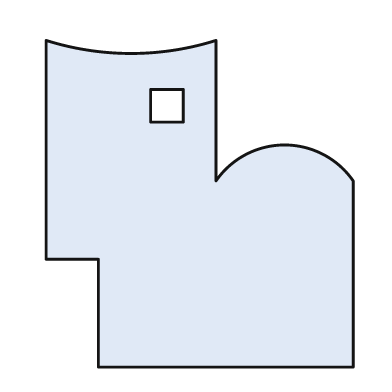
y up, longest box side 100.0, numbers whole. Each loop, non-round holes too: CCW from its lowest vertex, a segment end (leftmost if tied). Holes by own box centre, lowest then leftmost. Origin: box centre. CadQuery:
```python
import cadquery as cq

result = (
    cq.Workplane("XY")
    .moveTo(-31.0, -50.0)
    .lineTo(47.0, -50.0)
    .lineTo(47.0, 7.0)
    .threePointArc((26.0, 18.0), (5.0, 7.0))
    .lineTo(5.0, 50.0)
    .threePointArc((-21.0, 46.0), (-47.0, 50.0))
    .lineTo(-47.0, -17.0)
    .lineTo(-31.0, -17.0)
    .close()
    .moveTo(-15.0, 25.0)
    .lineTo(-5.0, 25.0)
    .lineTo(-5.0, 35.0)
    .lineTo(-15.0, 35.0)
    .close()
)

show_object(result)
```